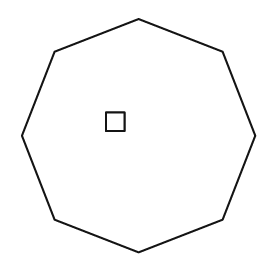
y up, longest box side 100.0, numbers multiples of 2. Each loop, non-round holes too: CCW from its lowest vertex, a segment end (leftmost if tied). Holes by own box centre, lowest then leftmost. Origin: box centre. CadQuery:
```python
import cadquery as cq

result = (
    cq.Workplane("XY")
    .moveTo(0.0, -50.0)
    .lineTo(36.0, -36.0)
    .lineTo(50.0, 0.0)
    .lineTo(36.0, 36.0)
    .lineTo(0.0, 50.0)
    .lineTo(-36.0, 36.0)
    .lineTo(-50.0, 0.0)
    .lineTo(-36.0, -36.0)
    .close()
    .moveTo(-14.0, 2.0)
    .lineTo(-6.0, 2.0)
    .lineTo(-6.0, 10.0)
    .lineTo(-14.0, 10.0)
    .close()
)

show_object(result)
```